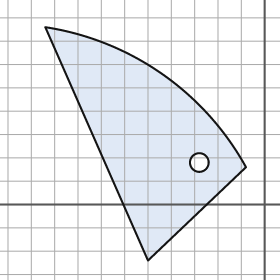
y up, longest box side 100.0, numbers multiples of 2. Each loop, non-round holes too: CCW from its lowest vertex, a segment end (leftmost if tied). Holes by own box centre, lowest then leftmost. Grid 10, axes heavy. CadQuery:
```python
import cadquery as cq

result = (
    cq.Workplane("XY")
    .moveTo(-50.0, -24.0)
    .lineTo(-8.0, 16.0)
    .threePointArc((-44.0, 56.0), (-94.0, 76.0))
    .close()
    .moveTo(-28.0, 18.0)
    .circle(4.0)
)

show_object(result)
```